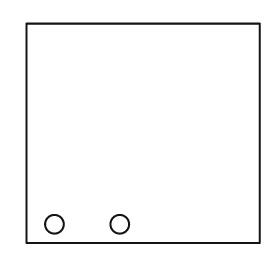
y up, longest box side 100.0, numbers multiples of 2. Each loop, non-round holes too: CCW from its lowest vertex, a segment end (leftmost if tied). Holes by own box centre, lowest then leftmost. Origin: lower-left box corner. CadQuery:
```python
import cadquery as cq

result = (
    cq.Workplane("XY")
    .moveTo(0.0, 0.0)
    .lineTo(100.0, 0.0)
    .lineTo(100.0, 94.0)
    .lineTo(0.0, 94.0)
    .close()
    .moveTo(12.0, 8.0)
    .circle(4.0)
    .moveTo(40.0, 8.0)
    .circle(4.0)
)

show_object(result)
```